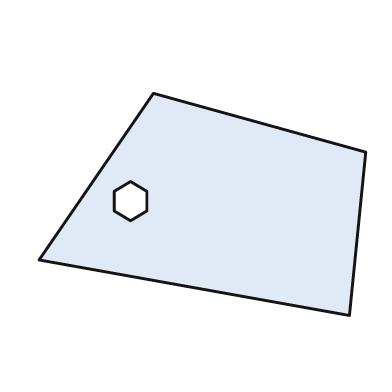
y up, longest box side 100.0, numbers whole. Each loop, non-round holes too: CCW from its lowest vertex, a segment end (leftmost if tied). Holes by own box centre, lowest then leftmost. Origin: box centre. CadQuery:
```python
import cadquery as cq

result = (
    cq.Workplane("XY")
    .moveTo(45.0, -34.0)
    .lineTo(50.0, 16.0)
    .lineTo(-15.0, 34.0)
    .lineTo(-50.0, -17.0)
    .close()
    .moveTo(-22.0, -5.0)
    .lineTo(-17.0, -2.0)
    .lineTo(-17.0, 4.0)
    .lineTo(-22.0, 7.0)
    .lineTo(-27.0, 4.0)
    .lineTo(-27.0, -2.0)
    .close()
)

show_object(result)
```